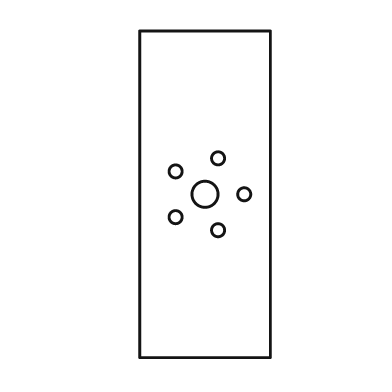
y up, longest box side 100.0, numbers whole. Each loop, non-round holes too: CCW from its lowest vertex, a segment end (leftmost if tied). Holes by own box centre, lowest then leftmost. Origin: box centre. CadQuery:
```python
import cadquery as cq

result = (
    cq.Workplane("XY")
    .moveTo(-20.0, -50.0)
    .lineTo(20.0, -50.0)
    .lineTo(20.0, 50.0)
    .lineTo(-20.0, 50.0)
    .close()
    .moveTo(4.0, -11.0)
    .circle(2.0)
    .moveTo(-9.0, -7.0)
    .circle(2.0)
    .moveTo(0.0, 0.0)
    .circle(4.0)
    .moveTo(12.0, 0.0)
    .circle(2.0)
    .moveTo(-9.0, 7.0)
    .circle(2.0)
    .moveTo(4.0, 11.0)
    .circle(2.0)
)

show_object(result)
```